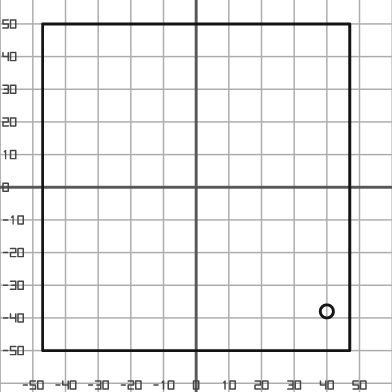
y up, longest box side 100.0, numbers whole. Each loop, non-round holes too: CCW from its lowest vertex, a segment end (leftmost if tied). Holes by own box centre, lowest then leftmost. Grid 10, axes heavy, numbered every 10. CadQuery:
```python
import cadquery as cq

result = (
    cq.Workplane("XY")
    .moveTo(-47.0, -50.0)
    .lineTo(47.0, -50.0)
    .lineTo(47.0, 50.0)
    .lineTo(-47.0, 50.0)
    .close()
    .moveTo(40.0, -38.0)
    .circle(2.0)
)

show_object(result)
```